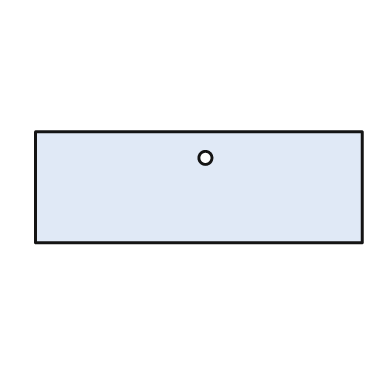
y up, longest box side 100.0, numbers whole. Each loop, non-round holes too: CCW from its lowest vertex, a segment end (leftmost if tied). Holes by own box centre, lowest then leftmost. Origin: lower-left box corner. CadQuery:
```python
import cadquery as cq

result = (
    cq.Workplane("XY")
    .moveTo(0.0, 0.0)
    .lineTo(100.0, 0.0)
    .lineTo(100.0, 34.0)
    .lineTo(0.0, 34.0)
    .close()
    .moveTo(52.0, 26.0)
    .circle(2.0)
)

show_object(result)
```